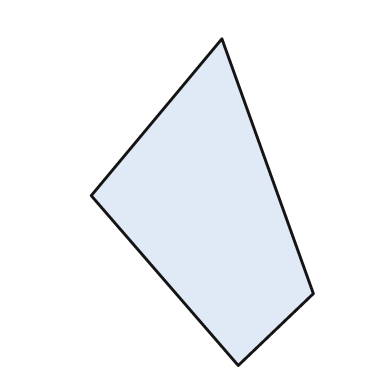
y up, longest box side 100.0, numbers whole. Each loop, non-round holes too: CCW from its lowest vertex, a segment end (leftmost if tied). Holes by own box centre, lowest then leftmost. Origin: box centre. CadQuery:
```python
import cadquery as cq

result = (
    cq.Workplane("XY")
    .moveTo(11.0, -50.0)
    .lineTo(34.0, -28.0)
    .lineTo(6.0, 50.0)
    .lineTo(-34.0, 2.0)
    .close()
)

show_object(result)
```